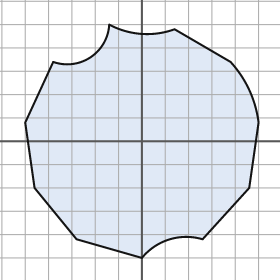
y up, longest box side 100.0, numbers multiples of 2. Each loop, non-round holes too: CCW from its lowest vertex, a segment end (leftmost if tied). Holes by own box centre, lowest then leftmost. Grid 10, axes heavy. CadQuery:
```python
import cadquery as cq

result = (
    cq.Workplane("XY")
    .moveTo(0.0, -50.0)
    .threePointArc((12.0, -42.0), (26.0, -42.0))
    .lineTo(46.0, -20.0)
    .lineTo(50.0, 8.0)
    .threePointArc((46.0, 22.0), (38.0, 34.0))
    .lineTo(14.0, 48.0)
    .threePointArc((0.0, 46.0), (-14.0, 50.0))
    .threePointArc((-22.0, 36.0), (-38.0, 34.0))
    .lineTo(-50.0, 8.0)
    .lineTo(-46.0, -20.0)
    .lineTo(-28.0, -42.0)
    .close()
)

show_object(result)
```